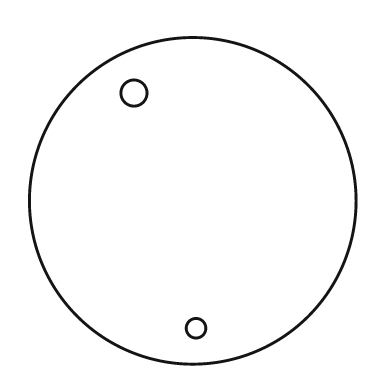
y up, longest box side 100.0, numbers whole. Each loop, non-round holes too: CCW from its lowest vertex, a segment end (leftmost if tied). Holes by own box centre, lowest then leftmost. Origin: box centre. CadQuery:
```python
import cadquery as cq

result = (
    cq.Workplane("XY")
    .moveTo(0.0, 0.0)
    .circle(50.0)
    .moveTo(1.0, -39.0)
    .circle(3.0)
    .moveTo(-18.0, 33.0)
    .circle(4.0)
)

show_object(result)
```